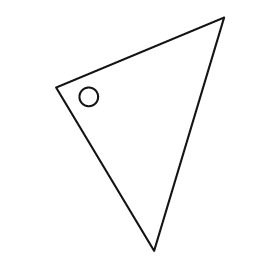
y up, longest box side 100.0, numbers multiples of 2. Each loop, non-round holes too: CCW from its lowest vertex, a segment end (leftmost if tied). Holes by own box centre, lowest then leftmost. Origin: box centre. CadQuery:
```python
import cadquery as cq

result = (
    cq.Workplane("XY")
    .moveTo(6.0, -50.0)
    .lineTo(36.0, 50.0)
    .lineTo(-36.0, 20.0)
    .close()
    .moveTo(-22.0, 16.0)
    .circle(4.0)
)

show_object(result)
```